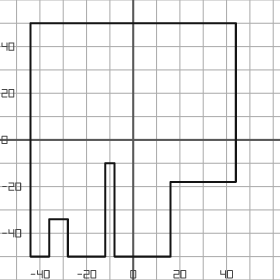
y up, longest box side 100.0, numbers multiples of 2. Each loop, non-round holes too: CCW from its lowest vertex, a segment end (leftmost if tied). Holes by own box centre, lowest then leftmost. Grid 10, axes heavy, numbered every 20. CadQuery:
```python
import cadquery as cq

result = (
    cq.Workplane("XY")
    .moveTo(-44.0, -50.0)
    .lineTo(-36.0, -50.0)
    .lineTo(-36.0, -34.0)
    .lineTo(-28.0, -34.0)
    .lineTo(-28.0, -50.0)
    .lineTo(-12.0, -50.0)
    .lineTo(-12.0, -10.0)
    .lineTo(-8.0, -10.0)
    .lineTo(-8.0, -50.0)
    .lineTo(16.0, -50.0)
    .lineTo(16.0, -18.0)
    .lineTo(44.0, -18.0)
    .lineTo(44.0, 50.0)
    .lineTo(-44.0, 50.0)
    .close()
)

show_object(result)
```